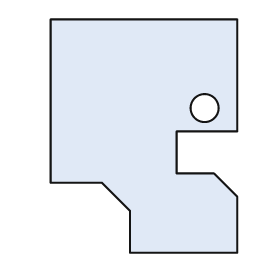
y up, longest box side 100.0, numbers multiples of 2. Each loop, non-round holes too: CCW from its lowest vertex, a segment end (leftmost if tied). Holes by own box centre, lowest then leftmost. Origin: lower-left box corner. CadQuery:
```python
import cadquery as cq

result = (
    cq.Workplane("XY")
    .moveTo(34.0, 0.0)
    .lineTo(80.0, 0.0)
    .lineTo(80.0, 24.0)
    .lineTo(70.0, 34.0)
    .lineTo(54.0, 34.0)
    .lineTo(54.0, 52.0)
    .lineTo(80.0, 52.0)
    .lineTo(80.0, 100.0)
    .lineTo(0.0, 100.0)
    .lineTo(0.0, 30.0)
    .lineTo(22.0, 30.0)
    .lineTo(34.0, 18.0)
    .close()
    .moveTo(66.0, 62.0)
    .circle(6.0)
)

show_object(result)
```